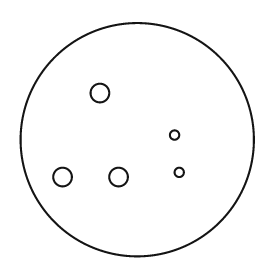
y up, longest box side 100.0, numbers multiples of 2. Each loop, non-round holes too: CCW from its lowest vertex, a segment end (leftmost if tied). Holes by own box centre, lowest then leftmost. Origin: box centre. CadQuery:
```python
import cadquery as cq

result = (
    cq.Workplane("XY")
    .moveTo(0.0, 0.0)
    .circle(50.0)
    .moveTo(-32.0, -16.0)
    .circle(4.0)
    .moveTo(-8.0, -16.0)
    .circle(4.0)
    .moveTo(18.0, -14.0)
    .circle(2.0)
    .moveTo(16.0, 2.0)
    .circle(2.0)
    .moveTo(-16.0, 20.0)
    .circle(4.0)
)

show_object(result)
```